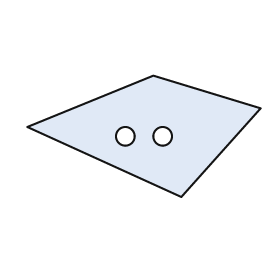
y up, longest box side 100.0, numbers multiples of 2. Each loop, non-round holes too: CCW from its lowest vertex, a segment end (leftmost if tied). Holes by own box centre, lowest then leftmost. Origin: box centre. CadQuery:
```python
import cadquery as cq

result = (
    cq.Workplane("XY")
    .moveTo(16.0, -26.0)
    .lineTo(50.0, 12.0)
    .lineTo(4.0, 26.0)
    .lineTo(-50.0, 4.0)
    .close()
    .moveTo(-8.0, 0.0)
    .circle(4.0)
    .moveTo(8.0, 0.0)
    .circle(4.0)
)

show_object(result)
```